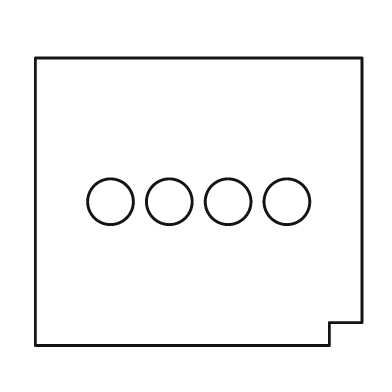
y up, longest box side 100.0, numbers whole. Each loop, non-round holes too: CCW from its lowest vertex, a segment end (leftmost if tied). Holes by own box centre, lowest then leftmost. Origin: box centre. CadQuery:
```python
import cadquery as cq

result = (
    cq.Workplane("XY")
    .moveTo(-50.0, -44.0)
    .lineTo(40.0, -44.0)
    .lineTo(40.0, -37.0)
    .lineTo(50.0, -37.0)
    .lineTo(50.0, 44.0)
    .lineTo(-50.0, 44.0)
    .close()
    .moveTo(-27.0, 0.0)
    .circle(7.0)
    .moveTo(-9.0, 0.0)
    .circle(7.0)
    .moveTo(9.0, 0.0)
    .circle(7.0)
    .moveTo(27.0, 0.0)
    .circle(7.0)
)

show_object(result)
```